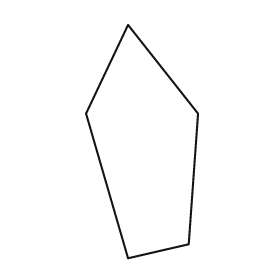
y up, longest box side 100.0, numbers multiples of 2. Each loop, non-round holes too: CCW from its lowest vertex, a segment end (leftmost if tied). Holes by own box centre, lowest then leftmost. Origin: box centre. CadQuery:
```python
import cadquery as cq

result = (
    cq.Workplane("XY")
    .moveTo(-6.0, -50.0)
    .lineTo(20.0, -44.0)
    .lineTo(24.0, 12.0)
    .lineTo(-6.0, 50.0)
    .lineTo(-24.0, 12.0)
    .close()
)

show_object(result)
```